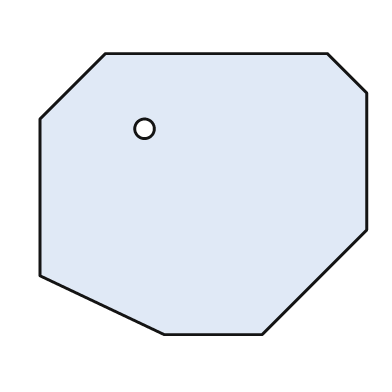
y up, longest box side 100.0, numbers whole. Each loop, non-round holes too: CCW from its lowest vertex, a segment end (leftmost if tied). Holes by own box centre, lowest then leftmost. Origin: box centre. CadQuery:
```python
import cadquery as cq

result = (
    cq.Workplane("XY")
    .moveTo(-12.0, -43.0)
    .lineTo(18.0, -43.0)
    .lineTo(50.0, -11.0)
    .lineTo(50.0, 31.0)
    .lineTo(38.0, 43.0)
    .lineTo(-30.0, 43.0)
    .lineTo(-50.0, 23.0)
    .lineTo(-50.0, -25.0)
    .close()
    .moveTo(-18.0, 20.0)
    .circle(3.0)
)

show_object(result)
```